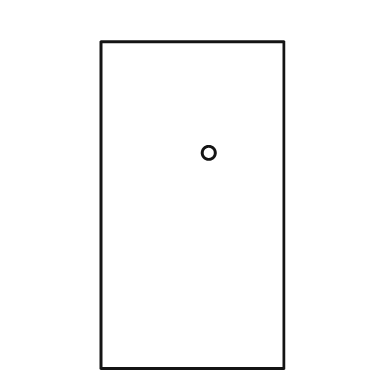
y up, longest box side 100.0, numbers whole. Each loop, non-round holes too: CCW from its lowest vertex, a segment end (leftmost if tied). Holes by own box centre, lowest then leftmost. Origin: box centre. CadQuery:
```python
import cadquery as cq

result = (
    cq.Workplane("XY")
    .moveTo(-28.0, -50.0)
    .lineTo(28.0, -50.0)
    .lineTo(28.0, 50.0)
    .lineTo(-28.0, 50.0)
    .close()
    .moveTo(5.0, 16.0)
    .circle(2.0)
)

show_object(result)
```